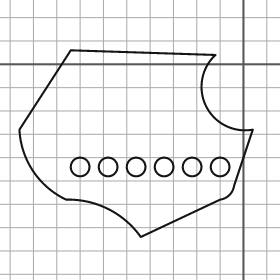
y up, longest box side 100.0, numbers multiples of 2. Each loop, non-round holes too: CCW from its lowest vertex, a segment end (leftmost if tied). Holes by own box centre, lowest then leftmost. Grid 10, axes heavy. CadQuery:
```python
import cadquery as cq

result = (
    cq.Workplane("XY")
    .moveTo(-44.0, -74.0)
    .lineTo(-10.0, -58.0)
    .threePointArc((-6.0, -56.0), (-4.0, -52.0))
    .lineTo(4.0, -28.0)
    .threePointArc((-16.0, -18.0), (-12.0, 4.0))
    .lineTo(-74.0, 6.0)
    .lineTo(-96.0, -28.0)
    .threePointArc((-90.0, -46.0), (-76.0, -58.0))
    .threePointArc((-58.0, -62.0), (-44.0, -74.0))
    .close()
    .moveTo(-70.0, -44.0)
    .circle(4.0)
    .moveTo(-58.0, -44.0)
    .circle(4.0)
    .moveTo(-46.0, -44.0)
    .circle(4.0)
    .moveTo(-34.0, -44.0)
    .circle(4.0)
    .moveTo(-22.0, -44.0)
    .circle(4.0)
    .moveTo(-10.0, -44.0)
    .circle(4.0)
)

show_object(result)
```